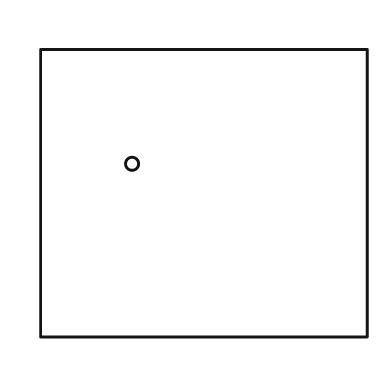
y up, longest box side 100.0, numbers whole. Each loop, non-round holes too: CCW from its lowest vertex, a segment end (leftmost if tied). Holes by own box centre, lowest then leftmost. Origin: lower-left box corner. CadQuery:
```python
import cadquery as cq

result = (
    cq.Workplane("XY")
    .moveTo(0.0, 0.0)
    .lineTo(100.0, 0.0)
    .lineTo(100.0, 88.0)
    .lineTo(0.0, 88.0)
    .close()
    .moveTo(28.0, 53.0)
    .circle(2.0)
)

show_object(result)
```